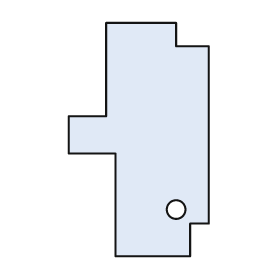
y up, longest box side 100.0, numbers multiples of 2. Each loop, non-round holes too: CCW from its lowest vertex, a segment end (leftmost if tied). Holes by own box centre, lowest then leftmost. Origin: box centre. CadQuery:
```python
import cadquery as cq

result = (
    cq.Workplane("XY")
    .moveTo(-10.0, -50.0)
    .lineTo(22.0, -50.0)
    .lineTo(22.0, -36.0)
    .lineTo(30.0, -36.0)
    .lineTo(30.0, 40.0)
    .lineTo(16.0, 40.0)
    .lineTo(16.0, 50.0)
    .lineTo(-14.0, 50.0)
    .lineTo(-14.0, 10.0)
    .lineTo(-30.0, 10.0)
    .lineTo(-30.0, -6.0)
    .lineTo(-10.0, -6.0)
    .close()
    .moveTo(16.0, -30.0)
    .circle(4.0)
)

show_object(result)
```